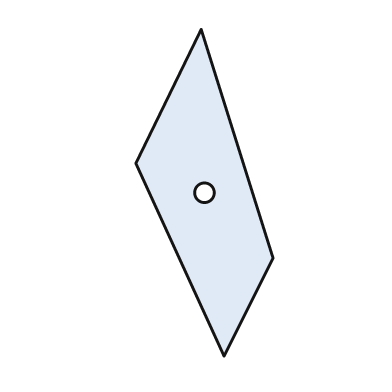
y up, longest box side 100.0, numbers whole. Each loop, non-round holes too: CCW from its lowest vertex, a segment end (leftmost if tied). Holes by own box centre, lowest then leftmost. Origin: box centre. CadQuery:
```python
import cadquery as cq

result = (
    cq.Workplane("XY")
    .moveTo(6.0, -50.0)
    .lineTo(21.0, -20.0)
    .lineTo(-1.0, 50.0)
    .lineTo(-21.0, 9.0)
    .close()
    .moveTo(0.0, 0.0)
    .circle(3.0)
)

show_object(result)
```